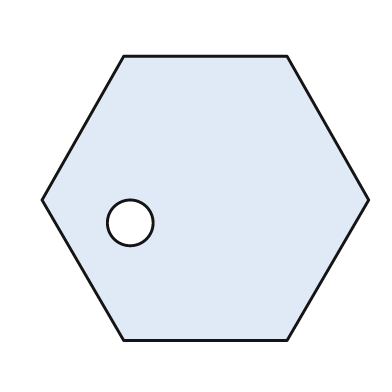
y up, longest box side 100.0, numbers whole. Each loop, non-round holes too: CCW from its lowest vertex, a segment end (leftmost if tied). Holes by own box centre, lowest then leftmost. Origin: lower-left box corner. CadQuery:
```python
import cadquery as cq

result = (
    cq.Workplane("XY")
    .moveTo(25.0, 0.0)
    .lineTo(75.0, 0.0)
    .lineTo(100.0, 43.0)
    .lineTo(75.0, 87.0)
    .lineTo(25.0, 87.0)
    .lineTo(0.0, 43.0)
    .close()
    .moveTo(27.0, 36.0)
    .circle(7.0)
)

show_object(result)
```